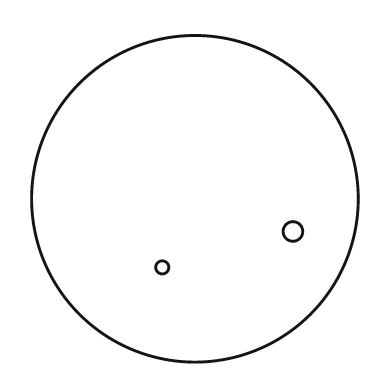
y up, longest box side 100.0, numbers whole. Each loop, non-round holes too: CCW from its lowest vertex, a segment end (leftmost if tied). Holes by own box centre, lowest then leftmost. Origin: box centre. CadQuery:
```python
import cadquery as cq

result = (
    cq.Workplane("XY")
    .moveTo(0.0, 0.0)
    .circle(50.0)
    .moveTo(-10.0, -21.0)
    .circle(2.0)
    .moveTo(30.0, -10.0)
    .circle(3.0)
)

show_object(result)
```